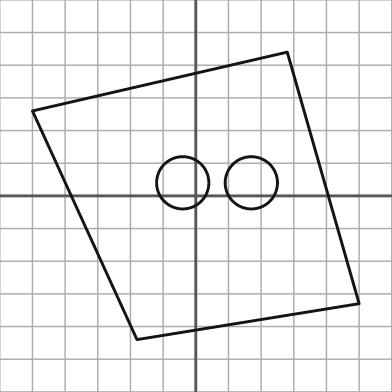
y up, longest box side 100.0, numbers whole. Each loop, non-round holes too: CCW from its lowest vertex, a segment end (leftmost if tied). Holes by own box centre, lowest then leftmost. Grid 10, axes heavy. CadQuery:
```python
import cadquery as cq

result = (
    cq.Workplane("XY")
    .moveTo(-18.0, -44.0)
    .lineTo(50.0, -33.0)
    .lineTo(28.0, 44.0)
    .lineTo(-50.0, 26.0)
    .close()
    .moveTo(-4.0, 4.0)
    .circle(8.0)
    .moveTo(17.0, 4.0)
    .circle(8.0)
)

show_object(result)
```